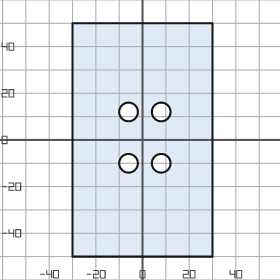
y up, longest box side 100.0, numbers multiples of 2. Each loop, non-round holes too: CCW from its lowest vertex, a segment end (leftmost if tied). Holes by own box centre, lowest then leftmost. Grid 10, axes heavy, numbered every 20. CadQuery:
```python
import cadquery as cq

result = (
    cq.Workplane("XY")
    .moveTo(-30.0, -50.0)
    .lineTo(30.0, -50.0)
    .lineTo(30.0, 50.0)
    .lineTo(-30.0, 50.0)
    .close()
    .moveTo(-6.0, -10.0)
    .circle(4.0)
    .moveTo(8.0, -10.0)
    .circle(4.0)
    .moveTo(-6.0, 12.0)
    .circle(4.0)
    .moveTo(8.0, 12.0)
    .circle(4.0)
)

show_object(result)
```